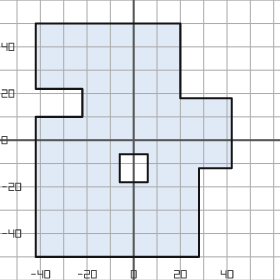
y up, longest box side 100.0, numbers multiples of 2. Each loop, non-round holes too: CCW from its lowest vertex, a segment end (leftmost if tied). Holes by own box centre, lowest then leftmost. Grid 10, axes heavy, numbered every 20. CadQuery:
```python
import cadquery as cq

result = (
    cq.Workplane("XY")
    .moveTo(-42.0, -50.0)
    .lineTo(28.0, -50.0)
    .lineTo(28.0, -12.0)
    .lineTo(42.0, -12.0)
    .lineTo(42.0, 18.0)
    .lineTo(20.0, 18.0)
    .lineTo(20.0, 50.0)
    .lineTo(-42.0, 50.0)
    .lineTo(-42.0, 22.0)
    .lineTo(-22.0, 22.0)
    .lineTo(-22.0, 10.0)
    .lineTo(-42.0, 10.0)
    .close()
    .moveTo(-6.0, -18.0)
    .lineTo(6.0, -18.0)
    .lineTo(6.0, -6.0)
    .lineTo(-6.0, -6.0)
    .close()
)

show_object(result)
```